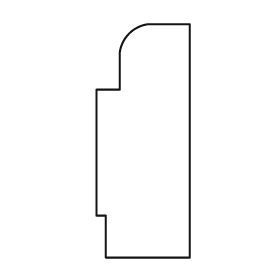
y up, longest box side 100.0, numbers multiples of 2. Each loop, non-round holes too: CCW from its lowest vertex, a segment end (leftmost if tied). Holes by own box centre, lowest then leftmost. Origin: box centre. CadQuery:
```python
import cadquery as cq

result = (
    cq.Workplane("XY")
    .moveTo(-16.0, -50.0)
    .lineTo(20.0, -50.0)
    .lineTo(20.0, 50.0)
    .lineTo(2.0, 50.0)
    .threePointArc((-6.0, 46.0), (-10.0, 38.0))
    .lineTo(-10.0, 22.0)
    .lineTo(-20.0, 22.0)
    .lineTo(-20.0, -32.0)
    .lineTo(-16.0, -32.0)
    .close()
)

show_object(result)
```